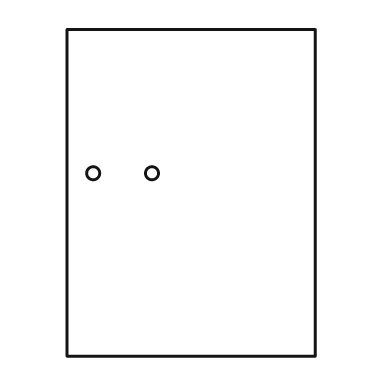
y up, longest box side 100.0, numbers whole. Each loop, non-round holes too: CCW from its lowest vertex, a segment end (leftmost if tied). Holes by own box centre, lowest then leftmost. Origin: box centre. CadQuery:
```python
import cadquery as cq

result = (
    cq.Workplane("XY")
    .moveTo(-38.0, -50.0)
    .lineTo(38.0, -50.0)
    .lineTo(38.0, 50.0)
    .lineTo(-38.0, 50.0)
    .close()
    .moveTo(-30.0, 6.0)
    .circle(2.0)
    .moveTo(-12.0, 6.0)
    .circle(2.0)
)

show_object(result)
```